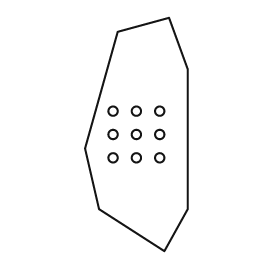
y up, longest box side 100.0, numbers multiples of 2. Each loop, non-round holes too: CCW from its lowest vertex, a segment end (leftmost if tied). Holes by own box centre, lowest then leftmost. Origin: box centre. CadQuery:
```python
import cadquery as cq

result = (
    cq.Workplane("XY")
    .moveTo(12.0, -50.0)
    .lineTo(22.0, -32.0)
    .lineTo(22.0, 28.0)
    .lineTo(14.0, 50.0)
    .lineTo(-8.0, 44.0)
    .lineTo(-22.0, -6.0)
    .lineTo(-16.0, -32.0)
    .close()
    .moveTo(-10.0, -10.0)
    .circle(2.0)
    .moveTo(0.0, -10.0)
    .circle(2.0)
    .moveTo(10.0, -10.0)
    .circle(2.0)
    .moveTo(-10.0, 0.0)
    .circle(2.0)
    .moveTo(0.0, 0.0)
    .circle(2.0)
    .moveTo(10.0, 0.0)
    .circle(2.0)
    .moveTo(-10.0, 10.0)
    .circle(2.0)
    .moveTo(0.0, 10.0)
    .circle(2.0)
    .moveTo(10.0, 10.0)
    .circle(2.0)
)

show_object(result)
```